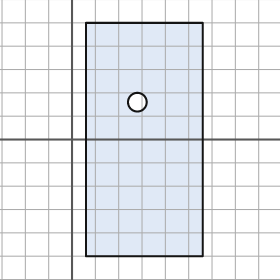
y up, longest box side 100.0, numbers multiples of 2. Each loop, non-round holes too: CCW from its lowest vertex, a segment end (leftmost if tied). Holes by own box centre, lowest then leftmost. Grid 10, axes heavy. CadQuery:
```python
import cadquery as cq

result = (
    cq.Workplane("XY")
    .moveTo(6.0, -50.0)
    .lineTo(56.0, -50.0)
    .lineTo(56.0, 50.0)
    .lineTo(6.0, 50.0)
    .close()
    .moveTo(28.0, 16.0)
    .circle(4.0)
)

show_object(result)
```